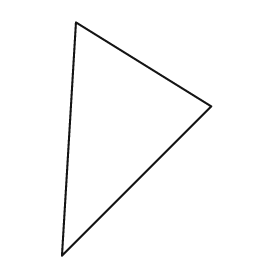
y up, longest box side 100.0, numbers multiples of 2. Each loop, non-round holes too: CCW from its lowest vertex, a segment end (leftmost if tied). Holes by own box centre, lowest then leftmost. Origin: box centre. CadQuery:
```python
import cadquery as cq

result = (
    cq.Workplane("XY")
    .moveTo(-32.0, -50.0)
    .lineTo(32.0, 14.0)
    .lineTo(-26.0, 50.0)
    .close()
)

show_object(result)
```